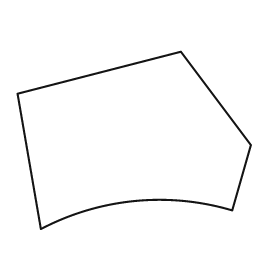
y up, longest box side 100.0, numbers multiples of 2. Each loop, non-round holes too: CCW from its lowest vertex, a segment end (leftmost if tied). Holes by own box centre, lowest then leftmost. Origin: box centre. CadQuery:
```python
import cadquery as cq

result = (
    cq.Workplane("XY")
    .moveTo(-40.0, -38.0)
    .threePointArc((0.0, -26.0), (42.0, -30.0))
    .lineTo(50.0, -2.0)
    .lineTo(20.0, 38.0)
    .lineTo(-50.0, 20.0)
    .close()
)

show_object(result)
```